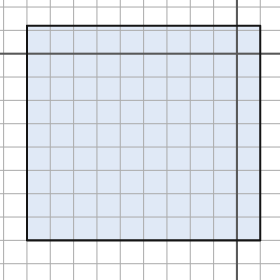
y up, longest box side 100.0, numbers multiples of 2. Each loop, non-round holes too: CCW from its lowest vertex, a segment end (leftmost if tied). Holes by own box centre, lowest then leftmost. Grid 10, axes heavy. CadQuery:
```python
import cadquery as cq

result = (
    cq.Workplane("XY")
    .moveTo(-90.0, -80.0)
    .lineTo(10.0, -80.0)
    .lineTo(10.0, 12.0)
    .lineTo(-90.0, 12.0)
    .close()
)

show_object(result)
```